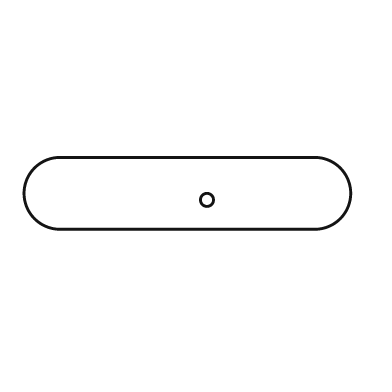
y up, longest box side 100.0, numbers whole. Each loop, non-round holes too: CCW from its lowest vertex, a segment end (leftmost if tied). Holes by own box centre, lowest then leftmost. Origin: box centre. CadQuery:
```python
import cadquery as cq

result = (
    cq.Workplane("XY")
    .moveTo(-39.0, -11.0)
    .lineTo(39.0, -11.0)
    .threePointArc((50.0, 0.0), (39.0, 11.0))
    .lineTo(-39.0, 11.0)
    .threePointArc((-50.0, 0.0), (-39.0, -11.0))
    .close()
    .moveTo(6.0, -2.0)
    .circle(2.0)
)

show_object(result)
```